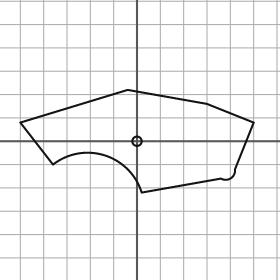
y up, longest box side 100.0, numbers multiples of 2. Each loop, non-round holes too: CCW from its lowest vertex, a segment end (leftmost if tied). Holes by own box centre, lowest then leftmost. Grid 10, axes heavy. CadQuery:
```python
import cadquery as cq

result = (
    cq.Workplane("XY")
    .moveTo(2.0, -22.0)
    .lineTo(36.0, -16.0)
    .threePointArc((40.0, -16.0), (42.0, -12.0))
    .lineTo(50.0, 8.0)
    .lineTo(30.0, 16.0)
    .lineTo(-4.0, 22.0)
    .lineTo(-50.0, 8.0)
    .lineTo(-36.0, -10.0)
    .threePointArc((-14.0, -6.0), (2.0, -22.0))
    .close()
    .moveTo(0.0, 0.0)
    .circle(2.0)
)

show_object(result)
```